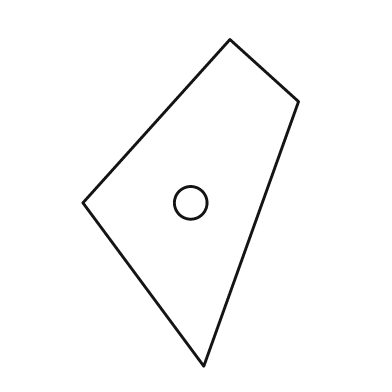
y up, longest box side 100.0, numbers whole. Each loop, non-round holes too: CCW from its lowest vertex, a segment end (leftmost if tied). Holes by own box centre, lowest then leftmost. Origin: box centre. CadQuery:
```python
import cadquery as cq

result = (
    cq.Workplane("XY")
    .moveTo(4.0, -50.0)
    .lineTo(33.0, 31.0)
    .lineTo(12.0, 50.0)
    .lineTo(-33.0, 0.0)
    .close()
    .moveTo(0.0, 0.0)
    .circle(5.0)
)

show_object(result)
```